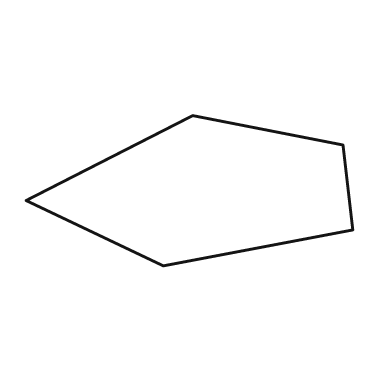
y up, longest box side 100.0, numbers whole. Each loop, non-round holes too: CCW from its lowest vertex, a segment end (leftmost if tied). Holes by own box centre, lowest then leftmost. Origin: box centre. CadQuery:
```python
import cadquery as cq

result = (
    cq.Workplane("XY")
    .moveTo(-8.0, -23.0)
    .lineTo(50.0, -12.0)
    .lineTo(47.0, 14.0)
    .lineTo(1.0, 23.0)
    .lineTo(-50.0, -3.0)
    .close()
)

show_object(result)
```